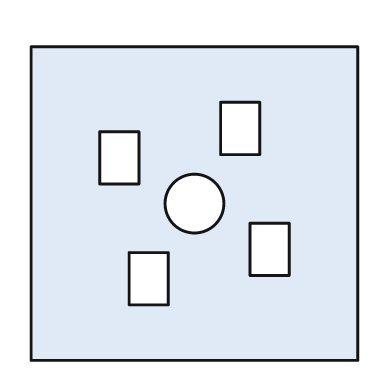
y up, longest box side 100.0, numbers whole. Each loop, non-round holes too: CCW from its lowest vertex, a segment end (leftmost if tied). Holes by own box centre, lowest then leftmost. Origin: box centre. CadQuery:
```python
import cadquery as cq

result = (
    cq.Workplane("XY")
    .moveTo(-50.0, -48.0)
    .lineTo(50.0, -48.0)
    .lineTo(50.0, 48.0)
    .lineTo(-50.0, 48.0)
    .close()
    .moveTo(-20.0, -31.0)
    .lineTo(-8.0, -31.0)
    .lineTo(-8.0, -15.0)
    .lineTo(-20.0, -15.0)
    .close()
    .moveTo(17.0, -22.0)
    .lineTo(29.0, -22.0)
    .lineTo(29.0, -6.0)
    .lineTo(17.0, -6.0)
    .close()
    .moveTo(0.0, 0.0)
    .circle(9.0)
    .moveTo(-29.0, 6.0)
    .lineTo(-17.0, 6.0)
    .lineTo(-17.0, 22.0)
    .lineTo(-29.0, 22.0)
    .close()
    .moveTo(8.0, 15.0)
    .lineTo(20.0, 15.0)
    .lineTo(20.0, 31.0)
    .lineTo(8.0, 31.0)
    .close()
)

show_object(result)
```